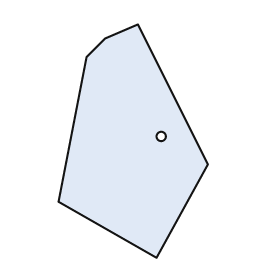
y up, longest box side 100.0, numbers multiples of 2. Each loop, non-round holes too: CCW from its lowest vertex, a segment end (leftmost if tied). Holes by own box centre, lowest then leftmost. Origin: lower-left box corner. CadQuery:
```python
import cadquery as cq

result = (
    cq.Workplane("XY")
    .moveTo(42.0, 0.0)
    .lineTo(64.0, 40.0)
    .lineTo(34.0, 100.0)
    .lineTo(20.0, 94.0)
    .lineTo(12.0, 86.0)
    .lineTo(0.0, 24.0)
    .close()
    .moveTo(44.0, 52.0)
    .circle(2.0)
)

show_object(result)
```